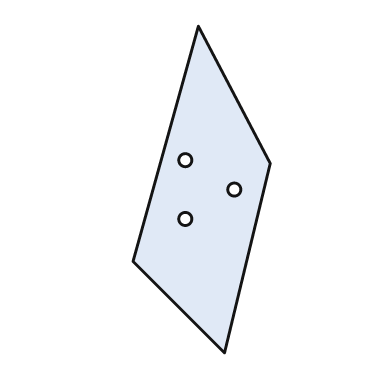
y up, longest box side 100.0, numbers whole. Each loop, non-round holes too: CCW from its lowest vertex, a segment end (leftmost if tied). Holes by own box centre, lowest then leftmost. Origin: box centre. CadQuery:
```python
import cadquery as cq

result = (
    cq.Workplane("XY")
    .moveTo(7.0, -50.0)
    .lineTo(21.0, 8.0)
    .lineTo(-1.0, 50.0)
    .lineTo(-21.0, -22.0)
    .close()
    .moveTo(-5.0, -9.0)
    .circle(2.0)
    .moveTo(10.0, 0.0)
    .circle(2.0)
    .moveTo(-5.0, 9.0)
    .circle(2.0)
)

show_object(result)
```